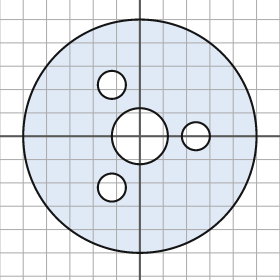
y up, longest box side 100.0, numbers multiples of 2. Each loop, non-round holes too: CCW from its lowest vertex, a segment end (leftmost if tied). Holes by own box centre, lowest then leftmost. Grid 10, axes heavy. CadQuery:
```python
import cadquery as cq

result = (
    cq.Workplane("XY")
    .moveTo(0.0, 0.0)
    .circle(50.0)
    .moveTo(-12.0, -22.0)
    .circle(6.0)
    .moveTo(0.0, 0.0)
    .circle(12.0)
    .moveTo(24.0, 0.0)
    .circle(6.0)
    .moveTo(-12.0, 22.0)
    .circle(6.0)
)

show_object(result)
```